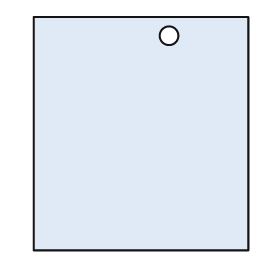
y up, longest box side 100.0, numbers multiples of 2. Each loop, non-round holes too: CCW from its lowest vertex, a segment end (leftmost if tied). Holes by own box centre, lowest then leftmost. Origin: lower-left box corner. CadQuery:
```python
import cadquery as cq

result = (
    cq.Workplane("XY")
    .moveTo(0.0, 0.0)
    .lineTo(92.0, 0.0)
    .lineTo(92.0, 100.0)
    .lineTo(0.0, 100.0)
    .close()
    .moveTo(58.0, 92.0)
    .circle(4.0)
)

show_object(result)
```